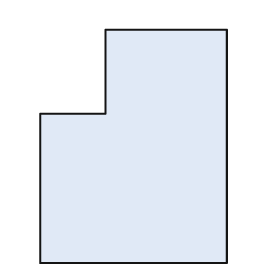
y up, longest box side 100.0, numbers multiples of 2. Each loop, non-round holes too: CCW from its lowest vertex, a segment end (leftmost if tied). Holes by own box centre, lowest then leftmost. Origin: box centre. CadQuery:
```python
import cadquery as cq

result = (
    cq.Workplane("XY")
    .moveTo(-40.0, -50.0)
    .lineTo(40.0, -50.0)
    .lineTo(40.0, 50.0)
    .lineTo(-12.0, 50.0)
    .lineTo(-12.0, 14.0)
    .lineTo(-40.0, 14.0)
    .close()
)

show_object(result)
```